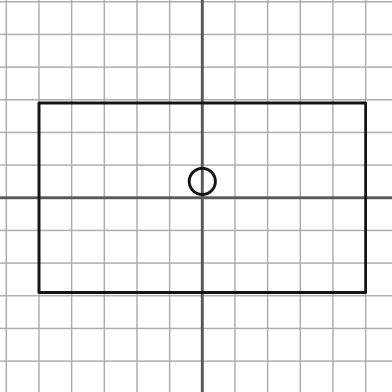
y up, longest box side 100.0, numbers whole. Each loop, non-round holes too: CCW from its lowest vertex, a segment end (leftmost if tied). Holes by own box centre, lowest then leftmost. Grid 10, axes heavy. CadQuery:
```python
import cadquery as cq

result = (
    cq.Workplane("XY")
    .moveTo(-50.0, -29.0)
    .lineTo(50.0, -29.0)
    .lineTo(50.0, 29.0)
    .lineTo(-50.0, 29.0)
    .close()
    .moveTo(0.0, 5.0)
    .circle(4.0)
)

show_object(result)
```